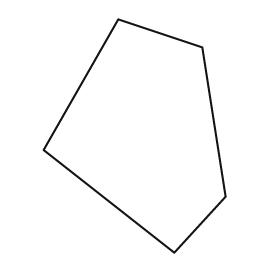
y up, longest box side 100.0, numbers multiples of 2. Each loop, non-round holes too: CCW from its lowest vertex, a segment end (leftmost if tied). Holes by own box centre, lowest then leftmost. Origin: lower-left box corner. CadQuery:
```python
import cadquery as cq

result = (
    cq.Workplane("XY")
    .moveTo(56.0, 0.0)
    .lineTo(78.0, 24.0)
    .lineTo(68.0, 88.0)
    .lineTo(32.0, 100.0)
    .lineTo(0.0, 44.0)
    .close()
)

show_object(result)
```